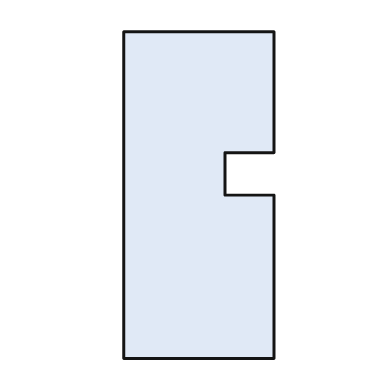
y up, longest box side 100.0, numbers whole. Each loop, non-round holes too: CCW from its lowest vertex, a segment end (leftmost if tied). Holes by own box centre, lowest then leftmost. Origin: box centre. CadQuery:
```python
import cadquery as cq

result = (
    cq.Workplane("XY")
    .moveTo(-23.0, -50.0)
    .lineTo(23.0, -50.0)
    .lineTo(23.0, 0.0)
    .lineTo(8.0, 0.0)
    .lineTo(8.0, 13.0)
    .lineTo(23.0, 13.0)
    .lineTo(23.0, 50.0)
    .lineTo(-23.0, 50.0)
    .close()
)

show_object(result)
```